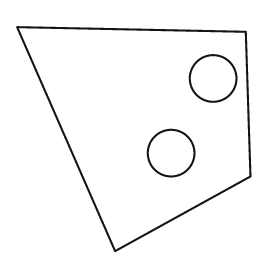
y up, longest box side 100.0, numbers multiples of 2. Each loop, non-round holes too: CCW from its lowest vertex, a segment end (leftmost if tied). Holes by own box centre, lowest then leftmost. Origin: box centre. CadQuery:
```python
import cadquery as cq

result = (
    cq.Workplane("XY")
    .moveTo(-8.0, -48.0)
    .lineTo(50.0, -16.0)
    .lineTo(48.0, 46.0)
    .lineTo(-50.0, 48.0)
    .close()
    .moveTo(16.0, -6.0)
    .circle(10.0)
    .moveTo(34.0, 26.0)
    .circle(10.0)
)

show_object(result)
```